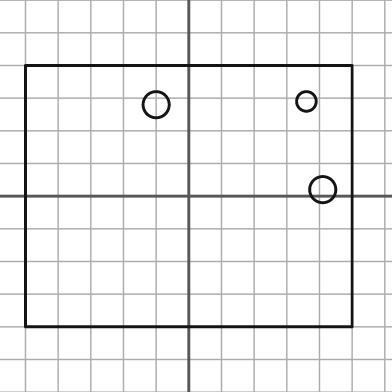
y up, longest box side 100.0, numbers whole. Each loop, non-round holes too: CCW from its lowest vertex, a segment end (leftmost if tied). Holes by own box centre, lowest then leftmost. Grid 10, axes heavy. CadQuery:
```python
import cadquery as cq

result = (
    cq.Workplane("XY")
    .moveTo(-50.0, -40.0)
    .lineTo(50.0, -40.0)
    .lineTo(50.0, 40.0)
    .lineTo(-50.0, 40.0)
    .close()
    .moveTo(41.0, 2.0)
    .circle(4.0)
    .moveTo(-10.0, 28.0)
    .circle(4.0)
    .moveTo(36.0, 29.0)
    .circle(3.0)
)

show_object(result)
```